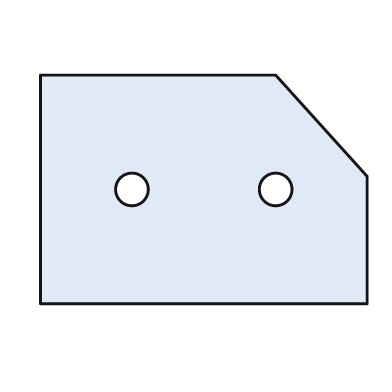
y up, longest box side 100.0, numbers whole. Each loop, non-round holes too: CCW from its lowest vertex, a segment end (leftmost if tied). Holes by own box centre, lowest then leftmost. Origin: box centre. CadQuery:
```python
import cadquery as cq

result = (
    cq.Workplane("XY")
    .moveTo(-50.0, -35.0)
    .lineTo(50.0, -35.0)
    .lineTo(50.0, 4.0)
    .lineTo(22.0, 35.0)
    .lineTo(-50.0, 35.0)
    .close()
    .moveTo(-22.0, 0.0)
    .circle(5.0)
    .moveTo(22.0, 0.0)
    .circle(5.0)
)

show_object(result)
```